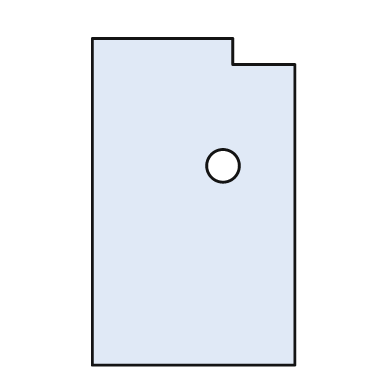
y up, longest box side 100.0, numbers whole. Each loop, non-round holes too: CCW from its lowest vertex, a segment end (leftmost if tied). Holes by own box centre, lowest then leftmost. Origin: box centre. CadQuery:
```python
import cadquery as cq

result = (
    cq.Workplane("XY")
    .moveTo(-31.0, -50.0)
    .lineTo(31.0, -50.0)
    .lineTo(31.0, 42.0)
    .lineTo(12.0, 42.0)
    .lineTo(12.0, 50.0)
    .lineTo(-31.0, 50.0)
    .close()
    .moveTo(9.0, 11.0)
    .circle(5.0)
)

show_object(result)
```